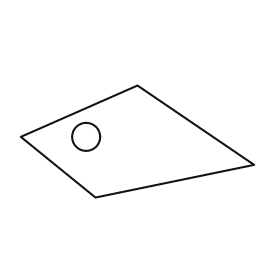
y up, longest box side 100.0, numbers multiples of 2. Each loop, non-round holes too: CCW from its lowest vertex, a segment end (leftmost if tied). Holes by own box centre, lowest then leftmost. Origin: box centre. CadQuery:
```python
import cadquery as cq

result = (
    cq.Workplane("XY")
    .moveTo(-18.0, -24.0)
    .lineTo(50.0, -10.0)
    .lineTo(0.0, 24.0)
    .lineTo(-50.0, 2.0)
    .close()
    .moveTo(-22.0, 2.0)
    .circle(6.0)
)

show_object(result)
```